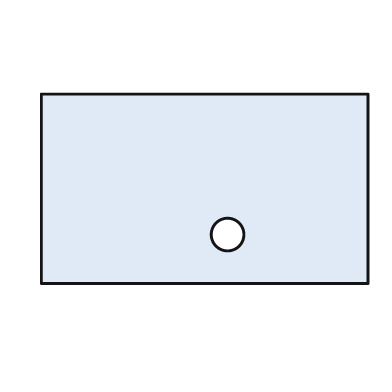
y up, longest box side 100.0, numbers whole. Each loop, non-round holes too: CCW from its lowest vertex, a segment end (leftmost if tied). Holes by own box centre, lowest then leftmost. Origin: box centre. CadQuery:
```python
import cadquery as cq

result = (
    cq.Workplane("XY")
    .moveTo(-50.0, -29.0)
    .lineTo(50.0, -29.0)
    .lineTo(50.0, 29.0)
    .lineTo(-50.0, 29.0)
    .close()
    .moveTo(7.0, -14.0)
    .circle(5.0)
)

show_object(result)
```